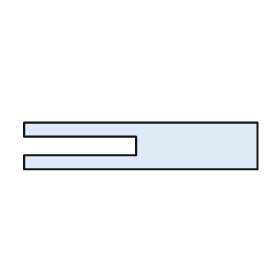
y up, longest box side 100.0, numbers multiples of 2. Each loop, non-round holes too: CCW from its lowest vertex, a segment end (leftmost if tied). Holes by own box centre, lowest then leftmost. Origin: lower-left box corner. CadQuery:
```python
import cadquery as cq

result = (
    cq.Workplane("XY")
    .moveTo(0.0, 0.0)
    .lineTo(100.0, 0.0)
    .lineTo(100.0, 20.0)
    .lineTo(0.0, 20.0)
    .lineTo(0.0, 14.0)
    .lineTo(48.0, 14.0)
    .lineTo(48.0, 6.0)
    .lineTo(0.0, 6.0)
    .close()
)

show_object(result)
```